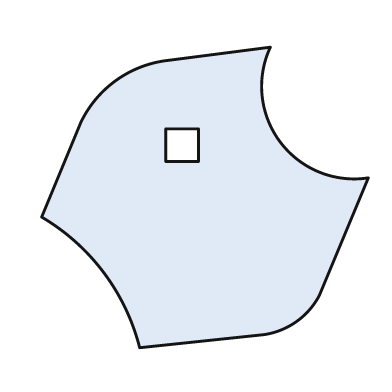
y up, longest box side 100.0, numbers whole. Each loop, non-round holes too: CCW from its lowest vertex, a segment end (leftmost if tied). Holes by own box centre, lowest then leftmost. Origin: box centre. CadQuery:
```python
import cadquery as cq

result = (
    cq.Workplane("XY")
    .moveTo(-20.0, -46.0)
    .lineTo(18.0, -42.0)
    .threePointArc((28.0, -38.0), (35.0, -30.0))
    .lineTo(50.0, 6.0)
    .threePointArc((23.0, 17.0), (20.0, 46.0))
    .lineTo(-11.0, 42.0)
    .threePointArc((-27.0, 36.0), (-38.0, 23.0))
    .lineTo(-50.0, -6.0)
    .threePointArc((-31.0, -23.0), (-20.0, -46.0))
    .close()
    .moveTo(-12.0, 11.0)
    .lineTo(-2.0, 11.0)
    .lineTo(-2.0, 21.0)
    .lineTo(-12.0, 21.0)
    .close()
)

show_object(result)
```